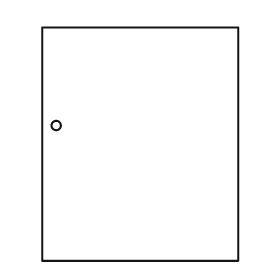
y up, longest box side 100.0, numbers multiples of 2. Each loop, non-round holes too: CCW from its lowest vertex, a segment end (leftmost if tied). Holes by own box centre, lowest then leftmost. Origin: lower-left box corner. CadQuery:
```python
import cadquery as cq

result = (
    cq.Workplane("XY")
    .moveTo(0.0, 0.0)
    .lineTo(84.0, 0.0)
    .lineTo(84.0, 100.0)
    .lineTo(0.0, 100.0)
    .close()
    .moveTo(6.0, 58.0)
    .circle(2.0)
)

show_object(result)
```